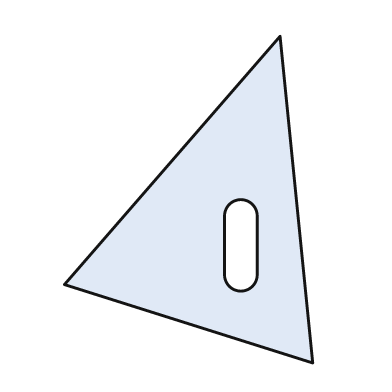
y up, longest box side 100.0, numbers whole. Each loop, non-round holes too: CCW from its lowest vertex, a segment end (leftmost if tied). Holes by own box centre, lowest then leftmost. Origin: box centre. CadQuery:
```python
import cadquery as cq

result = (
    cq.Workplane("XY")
    .moveTo(38.0, -50.0)
    .lineTo(28.0, 50.0)
    .lineTo(-38.0, -26.0)
    .close()
    .moveTo(11.0, -23.0)
    .threePointArc((16.0, -28.0), (21.0, -23.0))
    .lineTo(21.0, -5.0)
    .threePointArc((16.0, 0.0), (11.0, -5.0))
    .close()
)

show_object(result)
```